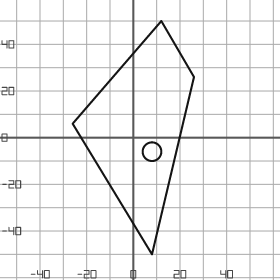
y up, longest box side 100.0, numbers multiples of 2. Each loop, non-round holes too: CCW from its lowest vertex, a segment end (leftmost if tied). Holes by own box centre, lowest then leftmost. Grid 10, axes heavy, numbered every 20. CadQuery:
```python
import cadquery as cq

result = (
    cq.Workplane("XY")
    .moveTo(8.0, -50.0)
    .lineTo(26.0, 26.0)
    .lineTo(12.0, 50.0)
    .lineTo(-26.0, 6.0)
    .close()
    .moveTo(8.0, -6.0)
    .circle(4.0)
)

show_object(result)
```